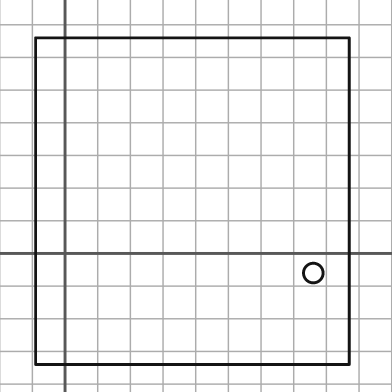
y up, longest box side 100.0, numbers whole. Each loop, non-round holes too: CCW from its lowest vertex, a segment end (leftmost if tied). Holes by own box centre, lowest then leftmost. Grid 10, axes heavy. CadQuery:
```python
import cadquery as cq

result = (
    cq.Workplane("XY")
    .moveTo(-9.0, -34.0)
    .lineTo(87.0, -34.0)
    .lineTo(87.0, 66.0)
    .lineTo(-9.0, 66.0)
    .close()
    .moveTo(76.0, -6.0)
    .circle(3.0)
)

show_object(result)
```